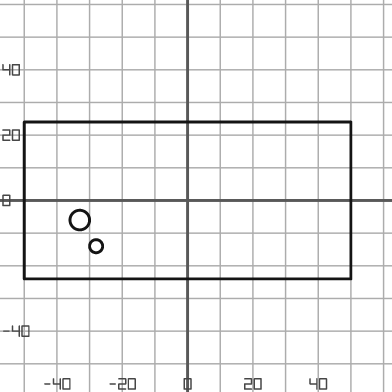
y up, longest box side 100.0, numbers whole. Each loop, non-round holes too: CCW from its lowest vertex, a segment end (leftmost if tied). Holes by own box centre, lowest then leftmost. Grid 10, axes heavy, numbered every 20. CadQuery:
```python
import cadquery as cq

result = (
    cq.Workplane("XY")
    .moveTo(-50.0, -24.0)
    .lineTo(50.0, -24.0)
    .lineTo(50.0, 24.0)
    .lineTo(-50.0, 24.0)
    .close()
    .moveTo(-28.0, -14.0)
    .circle(2.0)
    .moveTo(-33.0, -6.0)
    .circle(3.0)
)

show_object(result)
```